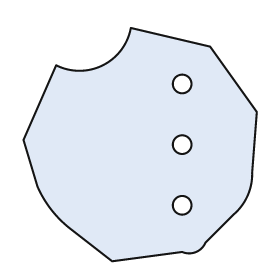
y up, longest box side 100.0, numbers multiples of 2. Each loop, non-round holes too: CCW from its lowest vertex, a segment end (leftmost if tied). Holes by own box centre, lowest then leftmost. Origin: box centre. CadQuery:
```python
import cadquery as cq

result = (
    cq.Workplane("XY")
    .moveTo(-12.0, -50.0)
    .lineTo(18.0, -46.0)
    .threePointArc((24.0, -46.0), (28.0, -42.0))
    .lineTo(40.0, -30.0)
    .threePointArc((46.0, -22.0), (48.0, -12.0))
    .lineTo(50.0, 14.0)
    .lineTo(30.0, 42.0)
    .lineTo(-4.0, 50.0)
    .threePointArc((-16.0, 34.0), (-36.0, 34.0))
    .lineTo(-50.0, 2.0)
    .lineTo(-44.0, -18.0)
    .threePointArc((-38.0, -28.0), (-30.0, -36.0))
    .close()
    .moveTo(18.0, -26.0)
    .circle(4.0)
    .moveTo(18.0, 0.0)
    .circle(4.0)
    .moveTo(18.0, 26.0)
    .circle(4.0)
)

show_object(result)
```